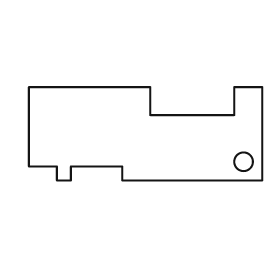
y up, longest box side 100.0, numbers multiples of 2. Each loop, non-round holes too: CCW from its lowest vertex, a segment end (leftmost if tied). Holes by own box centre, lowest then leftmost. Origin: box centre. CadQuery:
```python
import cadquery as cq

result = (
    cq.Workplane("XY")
    .moveTo(-38.0, -20.0)
    .lineTo(-32.0, -20.0)
    .lineTo(-32.0, -14.0)
    .lineTo(-10.0, -14.0)
    .lineTo(-10.0, -20.0)
    .lineTo(50.0, -20.0)
    .lineTo(50.0, 20.0)
    .lineTo(38.0, 20.0)
    .lineTo(38.0, 8.0)
    .lineTo(2.0, 8.0)
    .lineTo(2.0, 20.0)
    .lineTo(-50.0, 20.0)
    .lineTo(-50.0, -14.0)
    .lineTo(-38.0, -14.0)
    .close()
    .moveTo(42.0, -12.0)
    .circle(4.0)
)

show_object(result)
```